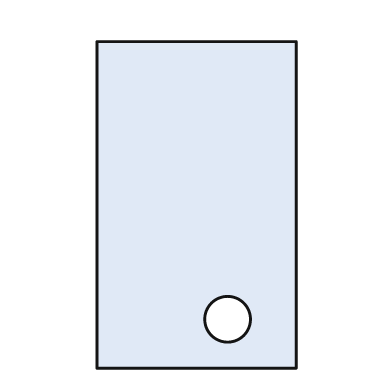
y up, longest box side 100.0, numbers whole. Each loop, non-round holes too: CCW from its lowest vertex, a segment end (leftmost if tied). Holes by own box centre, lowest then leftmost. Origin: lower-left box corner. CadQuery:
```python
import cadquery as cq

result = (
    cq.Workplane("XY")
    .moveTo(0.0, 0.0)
    .lineTo(61.0, 0.0)
    .lineTo(61.0, 100.0)
    .lineTo(0.0, 100.0)
    .close()
    .moveTo(40.0, 15.0)
    .circle(7.0)
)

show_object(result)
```